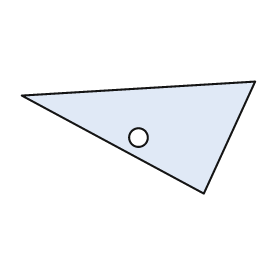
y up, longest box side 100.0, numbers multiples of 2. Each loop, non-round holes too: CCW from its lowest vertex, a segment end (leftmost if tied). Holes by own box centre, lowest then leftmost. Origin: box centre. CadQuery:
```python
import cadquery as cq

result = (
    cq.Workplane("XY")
    .moveTo(28.0, -24.0)
    .lineTo(50.0, 24.0)
    .lineTo(-50.0, 18.0)
    .close()
    .moveTo(0.0, 0.0)
    .circle(4.0)
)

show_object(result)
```